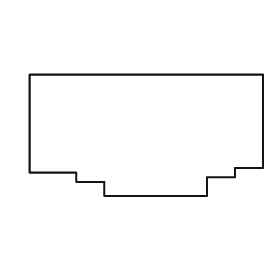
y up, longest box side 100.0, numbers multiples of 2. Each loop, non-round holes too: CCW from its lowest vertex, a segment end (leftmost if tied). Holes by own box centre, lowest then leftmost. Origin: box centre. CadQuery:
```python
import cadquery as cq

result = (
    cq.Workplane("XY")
    .moveTo(-18.0, -26.0)
    .lineTo(26.0, -26.0)
    .lineTo(26.0, -18.0)
    .lineTo(38.0, -18.0)
    .lineTo(38.0, -14.0)
    .lineTo(50.0, -14.0)
    .lineTo(50.0, 26.0)
    .lineTo(-50.0, 26.0)
    .lineTo(-50.0, -16.0)
    .lineTo(-30.0, -16.0)
    .lineTo(-30.0, -20.0)
    .lineTo(-18.0, -20.0)
    .close()
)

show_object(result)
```